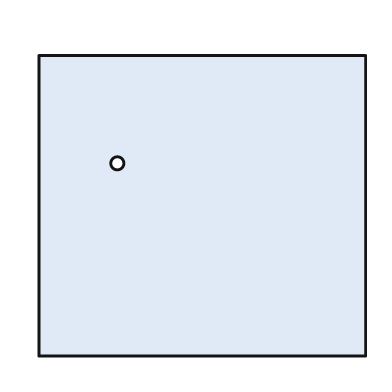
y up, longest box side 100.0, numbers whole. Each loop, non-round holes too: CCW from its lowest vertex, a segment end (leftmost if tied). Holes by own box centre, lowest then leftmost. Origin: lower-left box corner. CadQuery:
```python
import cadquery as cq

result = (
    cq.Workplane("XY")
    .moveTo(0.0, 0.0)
    .lineTo(100.0, 0.0)
    .lineTo(100.0, 92.0)
    .lineTo(0.0, 92.0)
    .close()
    .moveTo(24.0, 59.0)
    .circle(2.0)
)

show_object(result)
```